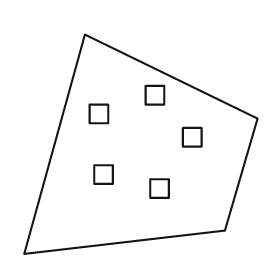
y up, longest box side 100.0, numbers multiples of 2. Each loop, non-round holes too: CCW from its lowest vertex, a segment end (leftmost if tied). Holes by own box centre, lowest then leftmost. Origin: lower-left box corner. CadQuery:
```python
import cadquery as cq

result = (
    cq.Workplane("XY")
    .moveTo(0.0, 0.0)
    .lineTo(86.0, 10.0)
    .lineTo(100.0, 58.0)
    .lineTo(26.0, 94.0)
    .close()
    .moveTo(54.0, 24.0)
    .lineTo(62.0, 24.0)
    .lineTo(62.0, 32.0)
    .lineTo(54.0, 32.0)
    .close()
    .moveTo(30.0, 30.0)
    .lineTo(38.0, 30.0)
    .lineTo(38.0, 38.0)
    .lineTo(30.0, 38.0)
    .close()
    .moveTo(68.0, 46.0)
    .lineTo(76.0, 46.0)
    .lineTo(76.0, 54.0)
    .lineTo(68.0, 54.0)
    .close()
    .moveTo(28.0, 56.0)
    .lineTo(36.0, 56.0)
    .lineTo(36.0, 64.0)
    .lineTo(28.0, 64.0)
    .close()
    .moveTo(52.0, 64.0)
    .lineTo(60.0, 64.0)
    .lineTo(60.0, 72.0)
    .lineTo(52.0, 72.0)
    .close()
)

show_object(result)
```